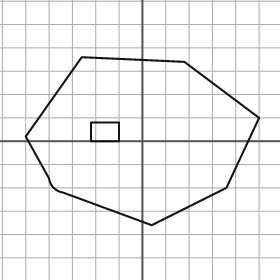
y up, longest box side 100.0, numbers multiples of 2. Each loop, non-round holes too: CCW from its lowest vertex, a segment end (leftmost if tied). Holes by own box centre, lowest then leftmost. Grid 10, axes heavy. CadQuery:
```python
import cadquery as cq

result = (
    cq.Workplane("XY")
    .moveTo(4.0, -36.0)
    .lineTo(36.0, -20.0)
    .lineTo(50.0, 10.0)
    .lineTo(18.0, 34.0)
    .lineTo(-26.0, 36.0)
    .lineTo(-50.0, 2.0)
    .lineTo(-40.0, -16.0)
    .threePointArc((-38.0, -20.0), (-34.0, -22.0))
    .close()
    .moveTo(-22.0, 0.0)
    .lineTo(-10.0, 0.0)
    .lineTo(-10.0, 8.0)
    .lineTo(-22.0, 8.0)
    .close()
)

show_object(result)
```